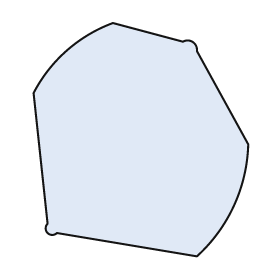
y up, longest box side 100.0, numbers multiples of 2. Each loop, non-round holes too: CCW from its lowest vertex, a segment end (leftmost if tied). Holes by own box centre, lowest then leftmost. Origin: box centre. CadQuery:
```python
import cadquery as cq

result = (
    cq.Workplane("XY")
    .moveTo(24.0, -50.0)
    .threePointArc((40.0, -28.0), (46.0, -2.0))
    .lineTo(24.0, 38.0)
    .threePointArc((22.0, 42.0), (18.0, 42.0))
    .lineTo(-12.0, 50.0)
    .threePointArc((-32.0, 38.0), (-46.0, 20.0))
    .lineTo(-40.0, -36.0)
    .threePointArc((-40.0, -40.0), (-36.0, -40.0))
    .close()
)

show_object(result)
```